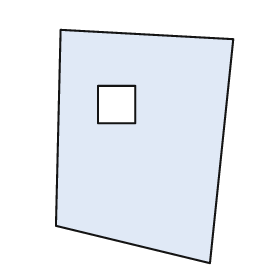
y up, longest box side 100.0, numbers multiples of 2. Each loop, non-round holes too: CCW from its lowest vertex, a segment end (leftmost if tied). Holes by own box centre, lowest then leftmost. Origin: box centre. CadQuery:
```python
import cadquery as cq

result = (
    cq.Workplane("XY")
    .moveTo(28.0, -50.0)
    .lineTo(38.0, 46.0)
    .lineTo(-36.0, 50.0)
    .lineTo(-38.0, -34.0)
    .close()
    .moveTo(-20.0, 10.0)
    .lineTo(-4.0, 10.0)
    .lineTo(-4.0, 26.0)
    .lineTo(-20.0, 26.0)
    .close()
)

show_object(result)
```